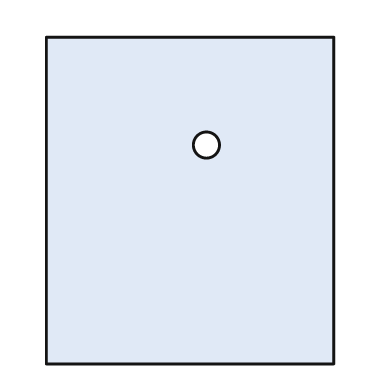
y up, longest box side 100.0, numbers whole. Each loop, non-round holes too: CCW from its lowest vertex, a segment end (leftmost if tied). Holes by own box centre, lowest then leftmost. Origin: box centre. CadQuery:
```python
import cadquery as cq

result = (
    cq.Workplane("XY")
    .moveTo(-44.0, -50.0)
    .lineTo(44.0, -50.0)
    .lineTo(44.0, 50.0)
    .lineTo(-44.0, 50.0)
    .close()
    .moveTo(5.0, 17.0)
    .circle(4.0)
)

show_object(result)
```